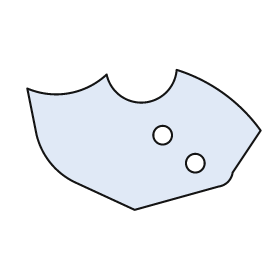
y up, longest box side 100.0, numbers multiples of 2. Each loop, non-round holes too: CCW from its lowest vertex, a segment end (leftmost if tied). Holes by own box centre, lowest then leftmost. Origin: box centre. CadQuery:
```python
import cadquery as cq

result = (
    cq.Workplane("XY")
    .moveTo(-4.0, -30.0)
    .lineTo(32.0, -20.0)
    .threePointArc((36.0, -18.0), (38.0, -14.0))
    .lineTo(50.0, 4.0)
    .threePointArc((34.0, 20.0), (14.0, 30.0))
    .threePointArc((0.0, 16.0), (-16.0, 28.0))
    .threePointArc((-32.0, 20.0), (-50.0, 22.0))
    .lineTo(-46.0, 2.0)
    .threePointArc((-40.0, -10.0), (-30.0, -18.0))
    .close()
    .moveTo(22.0, -10.0)
    .circle(4.0)
    .moveTo(8.0, 2.0)
    .circle(4.0)
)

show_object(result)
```